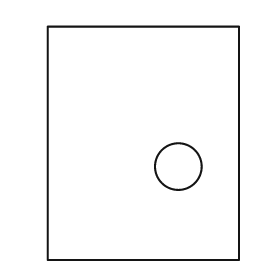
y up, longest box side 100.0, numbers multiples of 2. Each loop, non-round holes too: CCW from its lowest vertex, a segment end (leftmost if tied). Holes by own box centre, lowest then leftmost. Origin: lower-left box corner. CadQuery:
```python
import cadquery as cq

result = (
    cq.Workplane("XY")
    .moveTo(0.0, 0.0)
    .lineTo(82.0, 0.0)
    .lineTo(82.0, 100.0)
    .lineTo(0.0, 100.0)
    .close()
    .moveTo(56.0, 40.0)
    .circle(10.0)
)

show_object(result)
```